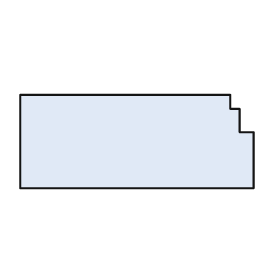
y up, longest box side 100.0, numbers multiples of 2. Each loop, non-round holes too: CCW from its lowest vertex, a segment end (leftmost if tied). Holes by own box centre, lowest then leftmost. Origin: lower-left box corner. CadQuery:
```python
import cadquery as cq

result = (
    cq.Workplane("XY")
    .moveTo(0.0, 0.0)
    .lineTo(100.0, 0.0)
    .lineTo(100.0, 24.0)
    .lineTo(94.0, 24.0)
    .lineTo(94.0, 34.0)
    .lineTo(90.0, 34.0)
    .lineTo(90.0, 40.0)
    .lineTo(0.0, 40.0)
    .close()
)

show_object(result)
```